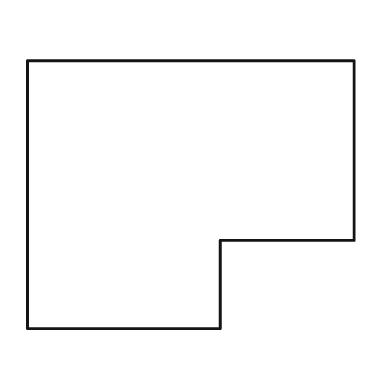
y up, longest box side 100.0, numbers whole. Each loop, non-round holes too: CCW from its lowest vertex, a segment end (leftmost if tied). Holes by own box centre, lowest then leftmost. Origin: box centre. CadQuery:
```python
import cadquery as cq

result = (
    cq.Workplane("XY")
    .moveTo(-50.0, -41.0)
    .lineTo(9.0, -41.0)
    .lineTo(9.0, -14.0)
    .lineTo(50.0, -14.0)
    .lineTo(50.0, 41.0)
    .lineTo(-50.0, 41.0)
    .close()
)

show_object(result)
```